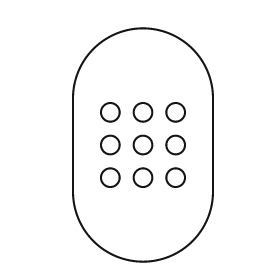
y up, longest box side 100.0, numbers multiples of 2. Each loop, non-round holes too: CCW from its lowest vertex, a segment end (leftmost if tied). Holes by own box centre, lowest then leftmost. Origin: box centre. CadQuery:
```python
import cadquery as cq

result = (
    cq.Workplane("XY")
    .moveTo(-30.0, -20.0)
    .threePointArc((0.0, -50.0), (30.0, -20.0))
    .lineTo(30.0, 20.0)
    .threePointArc((0.0, 50.0), (-30.0, 20.0))
    .close()
    .moveTo(-14.0, -14.0)
    .circle(4.0)
    .moveTo(0.0, -14.0)
    .circle(4.0)
    .moveTo(14.0, -14.0)
    .circle(4.0)
    .moveTo(-14.0, 0.0)
    .circle(4.0)
    .moveTo(0.0, 0.0)
    .circle(4.0)
    .moveTo(14.0, 0.0)
    .circle(4.0)
    .moveTo(-14.0, 14.0)
    .circle(4.0)
    .moveTo(0.0, 14.0)
    .circle(4.0)
    .moveTo(14.0, 14.0)
    .circle(4.0)
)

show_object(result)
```